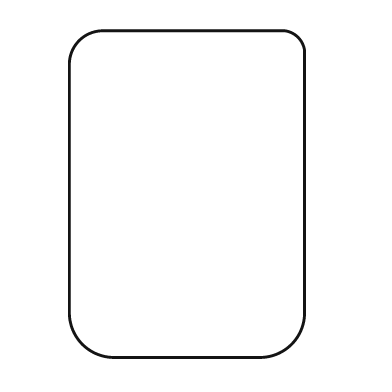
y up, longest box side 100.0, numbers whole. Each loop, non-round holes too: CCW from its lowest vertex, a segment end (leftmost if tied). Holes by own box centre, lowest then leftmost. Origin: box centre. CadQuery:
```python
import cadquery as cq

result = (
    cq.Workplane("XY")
    .moveTo(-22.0, -50.0)
    .lineTo(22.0, -50.0)
    .threePointArc((32.0, -46.0), (36.0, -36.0))
    .lineTo(36.0, 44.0)
    .threePointArc((34.0, 48.0), (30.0, 50.0))
    .lineTo(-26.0, 50.0)
    .threePointArc((-33.0, 47.0), (-36.0, 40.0))
    .lineTo(-36.0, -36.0)
    .threePointArc((-32.0, -46.0), (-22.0, -50.0))
    .close()
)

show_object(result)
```